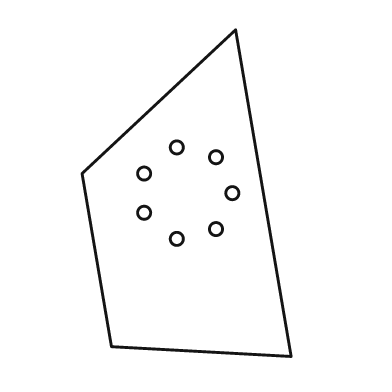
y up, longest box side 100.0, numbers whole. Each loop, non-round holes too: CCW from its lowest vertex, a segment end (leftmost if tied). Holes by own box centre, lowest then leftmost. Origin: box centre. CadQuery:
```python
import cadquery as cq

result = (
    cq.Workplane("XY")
    .moveTo(32.0, -50.0)
    .lineTo(15.0, 50.0)
    .lineTo(-32.0, 6.0)
    .lineTo(-23.0, -47.0)
    .close()
    .moveTo(-3.0, -14.0)
    .circle(2.0)
    .moveTo(9.0, -11.0)
    .circle(2.0)
    .moveTo(-13.0, -6.0)
    .circle(2.0)
    .moveTo(14.0, 0.0)
    .circle(2.0)
    .moveTo(-13.0, 6.0)
    .circle(2.0)
    .moveTo(9.0, 11.0)
    .circle(2.0)
    .moveTo(-3.0, 14.0)
    .circle(2.0)
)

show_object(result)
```